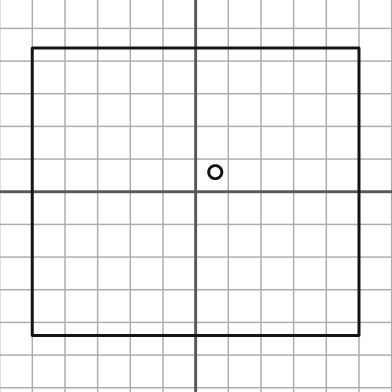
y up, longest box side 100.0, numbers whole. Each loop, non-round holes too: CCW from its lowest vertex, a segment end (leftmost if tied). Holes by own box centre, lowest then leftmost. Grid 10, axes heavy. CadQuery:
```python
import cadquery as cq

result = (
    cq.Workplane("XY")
    .moveTo(-50.0, -44.0)
    .lineTo(50.0, -44.0)
    .lineTo(50.0, 44.0)
    .lineTo(-50.0, 44.0)
    .close()
    .moveTo(6.0, 6.0)
    .circle(2.0)
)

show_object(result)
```